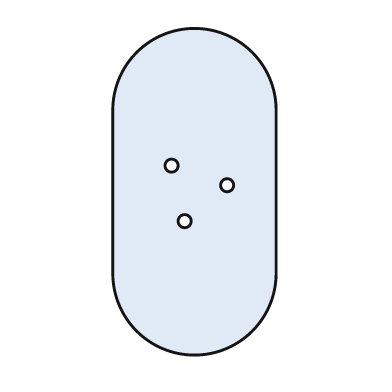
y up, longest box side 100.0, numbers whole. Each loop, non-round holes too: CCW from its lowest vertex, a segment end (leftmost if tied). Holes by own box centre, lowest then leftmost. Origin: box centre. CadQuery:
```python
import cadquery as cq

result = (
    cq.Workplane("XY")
    .moveTo(-25.0, -25.0)
    .threePointArc((0.0, -50.0), (25.0, -25.0))
    .lineTo(25.0, 25.0)
    .threePointArc((0.0, 50.0), (-25.0, 25.0))
    .close()
    .moveTo(-3.0, -9.0)
    .circle(2.0)
    .moveTo(10.0, 2.0)
    .circle(2.0)
    .moveTo(-7.0, 8.0)
    .circle(2.0)
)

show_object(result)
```